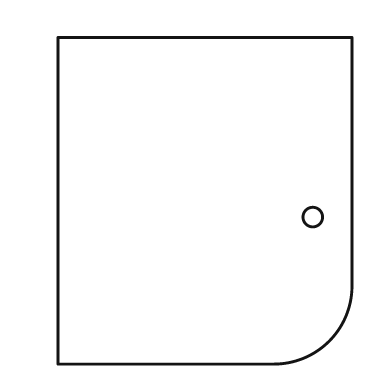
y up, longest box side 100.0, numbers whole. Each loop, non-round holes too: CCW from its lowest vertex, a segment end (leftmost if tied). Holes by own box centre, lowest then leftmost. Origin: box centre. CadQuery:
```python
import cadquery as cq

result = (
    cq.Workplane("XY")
    .moveTo(-45.0, -50.0)
    .lineTo(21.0, -50.0)
    .threePointArc((38.0, -43.0), (45.0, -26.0))
    .lineTo(45.0, 50.0)
    .lineTo(-45.0, 50.0)
    .close()
    .moveTo(33.0, -5.0)
    .circle(3.0)
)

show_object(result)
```